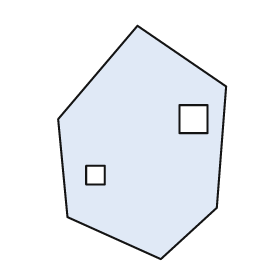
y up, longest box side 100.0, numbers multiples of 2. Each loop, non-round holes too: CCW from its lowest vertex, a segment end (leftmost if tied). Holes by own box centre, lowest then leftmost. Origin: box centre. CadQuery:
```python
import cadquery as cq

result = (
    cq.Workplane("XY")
    .moveTo(8.0, -50.0)
    .lineTo(32.0, -28.0)
    .lineTo(36.0, 24.0)
    .lineTo(-2.0, 50.0)
    .lineTo(-36.0, 10.0)
    .lineTo(-32.0, -32.0)
    .close()
    .moveTo(-24.0, -18.0)
    .lineTo(-16.0, -18.0)
    .lineTo(-16.0, -10.0)
    .lineTo(-24.0, -10.0)
    .close()
    .moveTo(16.0, 4.0)
    .lineTo(28.0, 4.0)
    .lineTo(28.0, 16.0)
    .lineTo(16.0, 16.0)
    .close()
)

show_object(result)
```